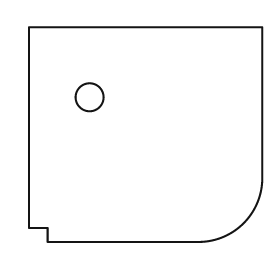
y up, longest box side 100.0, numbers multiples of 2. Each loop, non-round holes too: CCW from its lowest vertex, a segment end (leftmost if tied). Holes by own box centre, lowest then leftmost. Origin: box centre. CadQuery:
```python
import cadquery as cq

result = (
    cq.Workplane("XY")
    .moveTo(-42.0, -46.0)
    .lineTo(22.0, -46.0)
    .threePointArc((42.0, -38.0), (50.0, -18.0))
    .lineTo(50.0, 46.0)
    .lineTo(-50.0, 46.0)
    .lineTo(-50.0, -40.0)
    .lineTo(-42.0, -40.0)
    .close()
    .moveTo(-24.0, 16.0)
    .circle(6.0)
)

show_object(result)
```